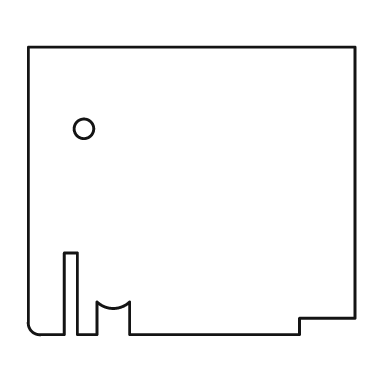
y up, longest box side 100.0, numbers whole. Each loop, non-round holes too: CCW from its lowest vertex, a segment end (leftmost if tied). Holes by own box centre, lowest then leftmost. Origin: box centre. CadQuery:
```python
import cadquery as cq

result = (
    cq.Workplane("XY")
    .moveTo(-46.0, -44.0)
    .lineTo(-39.0, -44.0)
    .lineTo(-39.0, -19.0)
    .lineTo(-35.0, -19.0)
    .lineTo(-35.0, -44.0)
    .lineTo(-29.0, -44.0)
    .lineTo(-29.0, -34.0)
    .threePointArc((-24.0, -36.0), (-19.0, -34.0))
    .lineTo(-19.0, -44.0)
    .lineTo(33.0, -44.0)
    .lineTo(33.0, -39.0)
    .lineTo(50.0, -39.0)
    .lineTo(50.0, 44.0)
    .lineTo(-50.0, 44.0)
    .lineTo(-50.0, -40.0)
    .threePointArc((-49.0, -43.0), (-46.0, -44.0))
    .close()
    .moveTo(-33.0, 19.0)
    .circle(3.0)
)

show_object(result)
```